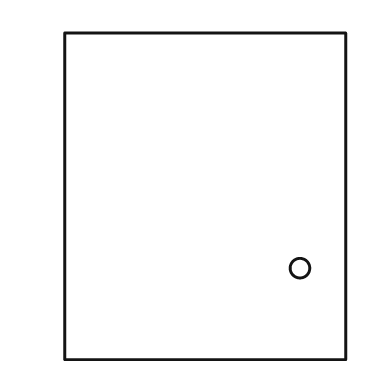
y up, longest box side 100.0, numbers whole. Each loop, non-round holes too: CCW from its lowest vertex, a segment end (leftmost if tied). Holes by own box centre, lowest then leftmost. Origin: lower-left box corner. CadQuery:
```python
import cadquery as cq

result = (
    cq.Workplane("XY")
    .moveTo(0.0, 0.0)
    .lineTo(86.0, 0.0)
    .lineTo(86.0, 100.0)
    .lineTo(0.0, 100.0)
    .close()
    .moveTo(72.0, 28.0)
    .circle(3.0)
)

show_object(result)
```